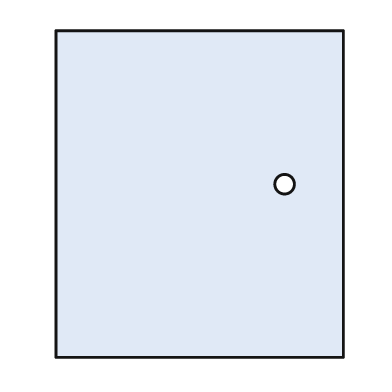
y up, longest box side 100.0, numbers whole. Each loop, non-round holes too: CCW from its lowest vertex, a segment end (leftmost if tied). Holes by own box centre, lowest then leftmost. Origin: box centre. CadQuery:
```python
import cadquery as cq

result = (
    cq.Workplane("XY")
    .moveTo(-44.0, -50.0)
    .lineTo(44.0, -50.0)
    .lineTo(44.0, 50.0)
    .lineTo(-44.0, 50.0)
    .close()
    .moveTo(26.0, 3.0)
    .circle(3.0)
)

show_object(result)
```